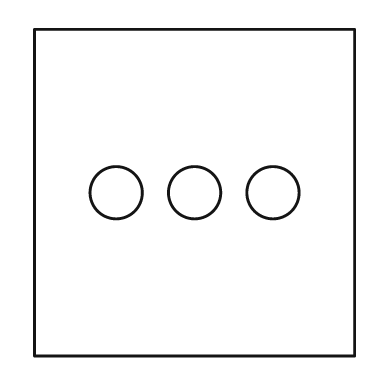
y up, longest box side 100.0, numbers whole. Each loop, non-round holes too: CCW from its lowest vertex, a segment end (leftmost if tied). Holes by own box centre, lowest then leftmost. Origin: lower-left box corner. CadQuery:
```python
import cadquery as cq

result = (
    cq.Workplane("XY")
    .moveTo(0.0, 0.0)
    .lineTo(98.0, 0.0)
    .lineTo(98.0, 100.0)
    .lineTo(0.0, 100.0)
    .close()
    .moveTo(25.0, 50.0)
    .circle(8.0)
    .moveTo(49.0, 50.0)
    .circle(8.0)
    .moveTo(73.0, 50.0)
    .circle(8.0)
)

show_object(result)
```